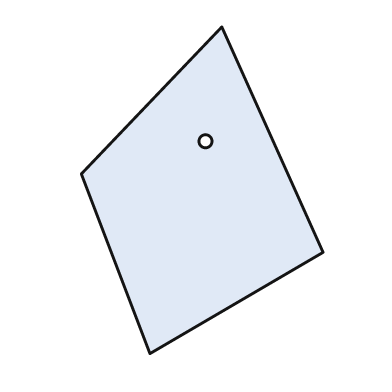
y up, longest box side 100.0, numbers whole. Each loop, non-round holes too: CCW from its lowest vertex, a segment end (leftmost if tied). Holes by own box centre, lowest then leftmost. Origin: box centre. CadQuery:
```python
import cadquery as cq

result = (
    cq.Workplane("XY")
    .moveTo(-16.0, -50.0)
    .lineTo(37.0, -19.0)
    .lineTo(6.0, 50.0)
    .lineTo(-37.0, 5.0)
    .close()
    .moveTo(1.0, 15.0)
    .circle(2.0)
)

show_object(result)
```